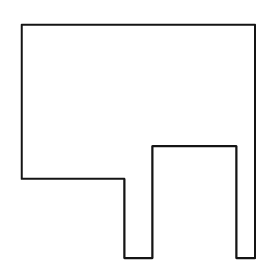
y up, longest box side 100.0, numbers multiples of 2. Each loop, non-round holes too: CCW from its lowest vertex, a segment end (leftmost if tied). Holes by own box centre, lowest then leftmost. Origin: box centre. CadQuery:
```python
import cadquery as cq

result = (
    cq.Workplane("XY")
    .moveTo(-6.0, -50.0)
    .lineTo(6.0, -50.0)
    .lineTo(6.0, -2.0)
    .lineTo(42.0, -2.0)
    .lineTo(42.0, -50.0)
    .lineTo(50.0, -50.0)
    .lineTo(50.0, 50.0)
    .lineTo(-50.0, 50.0)
    .lineTo(-50.0, -16.0)
    .lineTo(-6.0, -16.0)
    .close()
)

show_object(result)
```